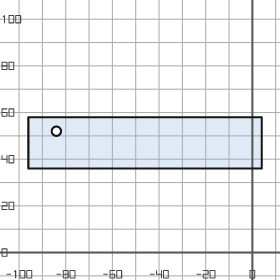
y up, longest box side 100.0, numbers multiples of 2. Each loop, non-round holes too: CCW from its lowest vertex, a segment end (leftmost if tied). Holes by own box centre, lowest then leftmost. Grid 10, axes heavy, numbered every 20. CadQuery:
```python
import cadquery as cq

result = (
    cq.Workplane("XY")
    .moveTo(-96.0, 36.0)
    .lineTo(4.0, 36.0)
    .lineTo(4.0, 58.0)
    .lineTo(-96.0, 58.0)
    .close()
    .moveTo(-84.0, 52.0)
    .circle(2.0)
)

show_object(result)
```